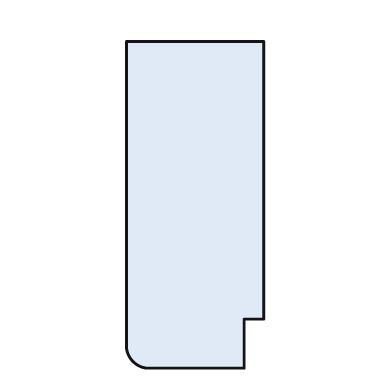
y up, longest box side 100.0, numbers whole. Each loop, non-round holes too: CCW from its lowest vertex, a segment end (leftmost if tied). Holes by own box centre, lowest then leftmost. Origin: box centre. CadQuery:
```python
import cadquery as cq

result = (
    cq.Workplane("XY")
    .moveTo(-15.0, -50.0)
    .lineTo(15.0, -50.0)
    .lineTo(15.0, -35.0)
    .lineTo(21.0, -35.0)
    .lineTo(21.0, 50.0)
    .lineTo(-21.0, 50.0)
    .lineTo(-21.0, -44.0)
    .threePointArc((-19.0, -48.0), (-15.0, -50.0))
    .close()
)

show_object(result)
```